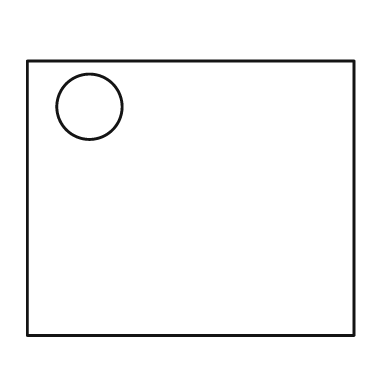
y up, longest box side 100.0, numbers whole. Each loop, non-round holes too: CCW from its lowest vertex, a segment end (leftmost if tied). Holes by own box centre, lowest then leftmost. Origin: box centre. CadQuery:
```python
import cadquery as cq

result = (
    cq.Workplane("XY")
    .moveTo(-50.0, -42.0)
    .lineTo(50.0, -42.0)
    .lineTo(50.0, 42.0)
    .lineTo(-50.0, 42.0)
    .close()
    .moveTo(-31.0, 28.0)
    .circle(10.0)
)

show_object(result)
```